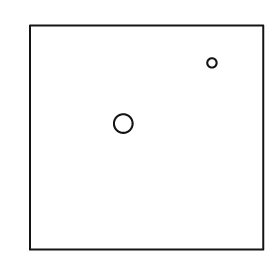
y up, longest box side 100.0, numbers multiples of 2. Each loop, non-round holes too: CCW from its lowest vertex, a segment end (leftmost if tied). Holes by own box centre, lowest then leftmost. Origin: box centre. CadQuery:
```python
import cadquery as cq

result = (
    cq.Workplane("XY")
    .moveTo(-50.0, -48.0)
    .lineTo(50.0, -48.0)
    .lineTo(50.0, 48.0)
    .lineTo(-50.0, 48.0)
    .close()
    .moveTo(-10.0, 6.0)
    .circle(4.0)
    .moveTo(28.0, 32.0)
    .circle(2.0)
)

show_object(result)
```